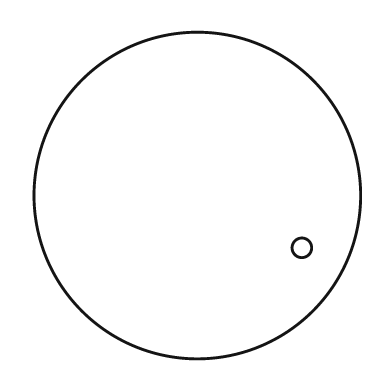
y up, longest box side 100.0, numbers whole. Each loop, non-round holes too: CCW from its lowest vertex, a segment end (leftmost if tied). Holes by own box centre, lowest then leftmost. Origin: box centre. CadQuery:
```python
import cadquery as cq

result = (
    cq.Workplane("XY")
    .moveTo(0.0, 0.0)
    .circle(50.0)
    .moveTo(32.0, -16.0)
    .circle(3.0)
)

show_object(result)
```